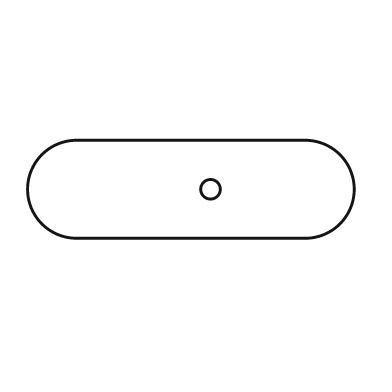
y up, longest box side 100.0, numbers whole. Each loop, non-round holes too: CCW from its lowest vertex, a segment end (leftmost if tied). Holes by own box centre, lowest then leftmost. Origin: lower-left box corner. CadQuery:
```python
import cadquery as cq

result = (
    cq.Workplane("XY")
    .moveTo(15.0, 0.0)
    .lineTo(85.0, 0.0)
    .threePointArc((100.0, 15.0), (85.0, 30.0))
    .lineTo(15.0, 30.0)
    .threePointArc((0.0, 15.0), (15.0, 0.0))
    .close()
    .moveTo(56.0, 15.0)
    .circle(3.0)
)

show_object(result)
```